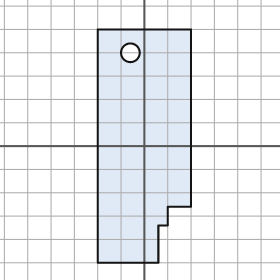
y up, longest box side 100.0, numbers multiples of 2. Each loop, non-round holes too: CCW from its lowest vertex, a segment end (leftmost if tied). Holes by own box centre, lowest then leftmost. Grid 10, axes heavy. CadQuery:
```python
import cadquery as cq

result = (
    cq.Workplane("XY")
    .moveTo(-20.0, -50.0)
    .lineTo(6.0, -50.0)
    .lineTo(6.0, -34.0)
    .lineTo(10.0, -34.0)
    .lineTo(10.0, -26.0)
    .lineTo(20.0, -26.0)
    .lineTo(20.0, 50.0)
    .lineTo(-20.0, 50.0)
    .close()
    .moveTo(-6.0, 40.0)
    .circle(4.0)
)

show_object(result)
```